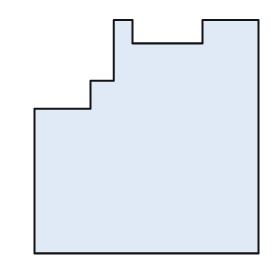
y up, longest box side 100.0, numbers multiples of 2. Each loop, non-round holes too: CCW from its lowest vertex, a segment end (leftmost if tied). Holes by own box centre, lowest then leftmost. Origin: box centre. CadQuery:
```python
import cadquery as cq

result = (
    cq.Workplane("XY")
    .moveTo(-48.0, -50.0)
    .lineTo(48.0, -50.0)
    .lineTo(48.0, 50.0)
    .lineTo(24.0, 50.0)
    .lineTo(24.0, 40.0)
    .lineTo(-6.0, 40.0)
    .lineTo(-6.0, 50.0)
    .lineTo(-14.0, 50.0)
    .lineTo(-14.0, 24.0)
    .lineTo(-24.0, 24.0)
    .lineTo(-24.0, 12.0)
    .lineTo(-48.0, 12.0)
    .close()
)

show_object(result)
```